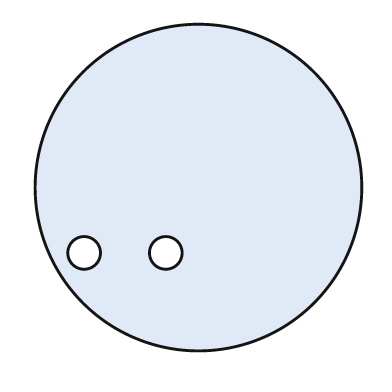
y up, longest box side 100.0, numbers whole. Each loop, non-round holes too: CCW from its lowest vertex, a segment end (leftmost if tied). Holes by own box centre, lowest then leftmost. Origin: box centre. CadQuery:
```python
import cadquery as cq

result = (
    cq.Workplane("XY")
    .moveTo(0.0, 0.0)
    .circle(50.0)
    .moveTo(-35.0, -20.0)
    .circle(5.0)
    .moveTo(-10.0, -20.0)
    .circle(5.0)
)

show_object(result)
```